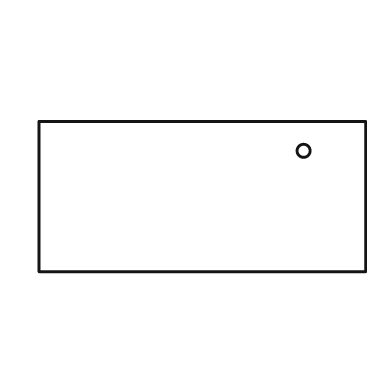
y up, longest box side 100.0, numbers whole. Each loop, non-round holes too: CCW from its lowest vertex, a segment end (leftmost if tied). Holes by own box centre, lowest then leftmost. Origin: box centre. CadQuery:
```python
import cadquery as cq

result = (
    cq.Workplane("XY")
    .moveTo(-50.0, -23.0)
    .lineTo(50.0, -23.0)
    .lineTo(50.0, 23.0)
    .lineTo(-50.0, 23.0)
    .close()
    .moveTo(31.0, 14.0)
    .circle(2.0)
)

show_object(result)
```